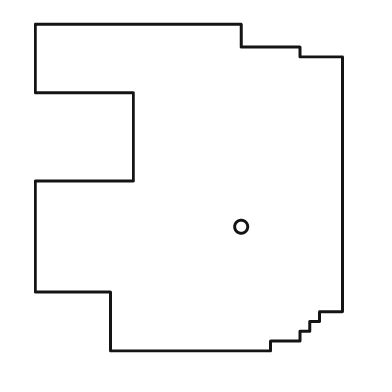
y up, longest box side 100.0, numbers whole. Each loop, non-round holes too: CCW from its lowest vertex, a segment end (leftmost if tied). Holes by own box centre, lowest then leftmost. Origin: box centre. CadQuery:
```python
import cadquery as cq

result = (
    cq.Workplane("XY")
    .moveTo(-24.0, -50.0)
    .lineTo(25.0, -50.0)
    .lineTo(25.0, -47.0)
    .lineTo(34.0, -47.0)
    .lineTo(34.0, -44.0)
    .lineTo(37.0, -44.0)
    .lineTo(37.0, -41.0)
    .lineTo(40.0, -41.0)
    .lineTo(40.0, -38.0)
    .lineTo(47.0, -38.0)
    .lineTo(47.0, 40.0)
    .lineTo(34.0, 40.0)
    .lineTo(34.0, 43.0)
    .lineTo(16.0, 43.0)
    .lineTo(16.0, 50.0)
    .lineTo(-47.0, 50.0)
    .lineTo(-47.0, 29.0)
    .lineTo(-17.0, 29.0)
    .lineTo(-17.0, 2.0)
    .lineTo(-47.0, 2.0)
    .lineTo(-47.0, -32.0)
    .lineTo(-24.0, -32.0)
    .close()
    .moveTo(16.0, -12.0)
    .circle(2.0)
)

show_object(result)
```